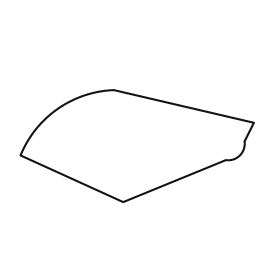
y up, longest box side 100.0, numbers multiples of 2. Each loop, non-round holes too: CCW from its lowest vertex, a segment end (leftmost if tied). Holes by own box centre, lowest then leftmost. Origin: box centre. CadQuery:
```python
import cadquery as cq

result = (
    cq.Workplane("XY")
    .moveTo(-6.0, -24.0)
    .lineTo(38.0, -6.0)
    .threePointArc((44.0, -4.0), (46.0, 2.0))
    .lineTo(50.0, 10.0)
    .lineTo(-10.0, 24.0)
    .threePointArc((-34.0, 16.0), (-50.0, -4.0))
    .close()
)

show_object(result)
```